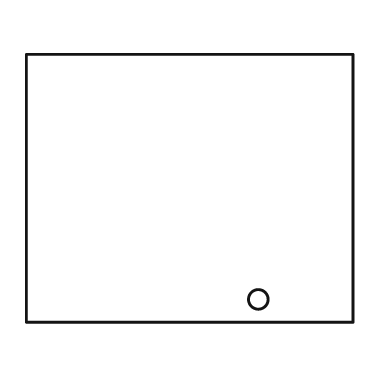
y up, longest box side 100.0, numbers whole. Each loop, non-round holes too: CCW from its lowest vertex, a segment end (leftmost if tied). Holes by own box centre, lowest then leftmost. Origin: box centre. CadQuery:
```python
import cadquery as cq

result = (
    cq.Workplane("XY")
    .moveTo(-50.0, -41.0)
    .lineTo(50.0, -41.0)
    .lineTo(50.0, 41.0)
    .lineTo(-50.0, 41.0)
    .close()
    .moveTo(21.0, -34.0)
    .circle(3.0)
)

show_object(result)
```